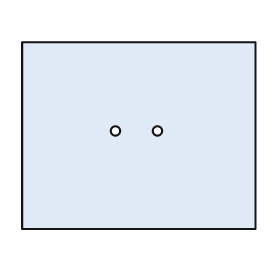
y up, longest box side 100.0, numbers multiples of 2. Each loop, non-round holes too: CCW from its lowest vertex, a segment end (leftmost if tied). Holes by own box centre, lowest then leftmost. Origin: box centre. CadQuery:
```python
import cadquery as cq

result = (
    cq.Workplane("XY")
    .moveTo(-50.0, -40.0)
    .lineTo(50.0, -40.0)
    .lineTo(50.0, 40.0)
    .lineTo(-50.0, 40.0)
    .close()
    .moveTo(-10.0, 2.0)
    .circle(2.0)
    .moveTo(8.0, 2.0)
    .circle(2.0)
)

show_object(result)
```